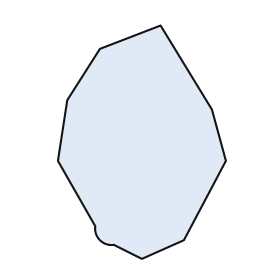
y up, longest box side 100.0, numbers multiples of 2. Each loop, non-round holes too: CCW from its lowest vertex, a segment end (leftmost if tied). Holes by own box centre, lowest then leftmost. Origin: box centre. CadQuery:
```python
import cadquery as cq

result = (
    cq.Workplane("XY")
    .moveTo(0.0, -50.0)
    .lineTo(18.0, -42.0)
    .lineTo(36.0, -8.0)
    .lineTo(30.0, 14.0)
    .lineTo(8.0, 50.0)
    .lineTo(-18.0, 40.0)
    .lineTo(-32.0, 18.0)
    .lineTo(-36.0, -8.0)
    .lineTo(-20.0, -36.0)
    .threePointArc((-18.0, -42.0), (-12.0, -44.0))
    .close()
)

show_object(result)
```